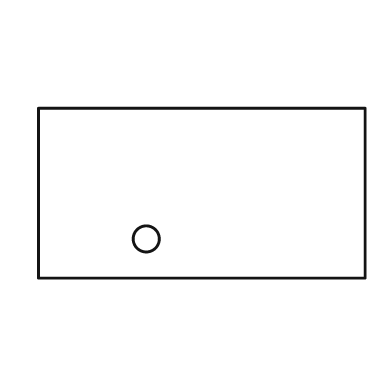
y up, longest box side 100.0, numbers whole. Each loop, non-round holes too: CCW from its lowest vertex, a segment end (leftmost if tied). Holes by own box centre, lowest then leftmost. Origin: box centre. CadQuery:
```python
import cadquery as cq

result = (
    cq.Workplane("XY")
    .moveTo(-50.0, -26.0)
    .lineTo(50.0, -26.0)
    .lineTo(50.0, 26.0)
    .lineTo(-50.0, 26.0)
    .close()
    .moveTo(-17.0, -14.0)
    .circle(4.0)
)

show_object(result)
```